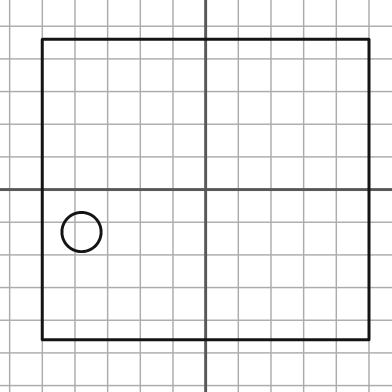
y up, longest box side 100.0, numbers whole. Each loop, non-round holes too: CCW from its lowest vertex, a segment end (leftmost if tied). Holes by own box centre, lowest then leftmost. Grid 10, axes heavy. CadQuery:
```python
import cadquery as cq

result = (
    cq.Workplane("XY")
    .moveTo(-50.0, -46.0)
    .lineTo(50.0, -46.0)
    .lineTo(50.0, 46.0)
    .lineTo(-50.0, 46.0)
    .close()
    .moveTo(-38.0, -13.0)
    .circle(6.0)
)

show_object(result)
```